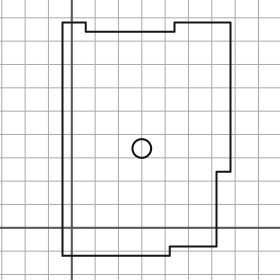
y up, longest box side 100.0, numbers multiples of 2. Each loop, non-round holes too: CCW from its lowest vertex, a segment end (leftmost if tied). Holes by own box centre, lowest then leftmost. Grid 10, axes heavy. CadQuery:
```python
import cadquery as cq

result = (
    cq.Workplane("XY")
    .moveTo(-4.0, -12.0)
    .lineTo(42.0, -12.0)
    .lineTo(42.0, -8.0)
    .lineTo(62.0, -8.0)
    .lineTo(62.0, 24.0)
    .lineTo(68.0, 24.0)
    .lineTo(68.0, 88.0)
    .lineTo(44.0, 88.0)
    .lineTo(44.0, 84.0)
    .lineTo(6.0, 84.0)
    .lineTo(6.0, 88.0)
    .lineTo(-4.0, 88.0)
    .close()
    .moveTo(30.0, 34.0)
    .circle(4.0)
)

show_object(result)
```